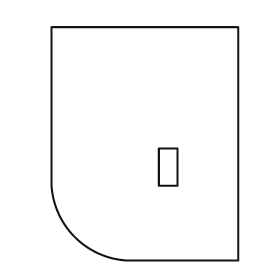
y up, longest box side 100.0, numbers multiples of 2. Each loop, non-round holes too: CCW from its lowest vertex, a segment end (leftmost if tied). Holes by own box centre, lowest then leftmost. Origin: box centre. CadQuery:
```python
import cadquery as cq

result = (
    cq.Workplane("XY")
    .moveTo(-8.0, -50.0)
    .lineTo(40.0, -50.0)
    .lineTo(40.0, 50.0)
    .lineTo(-40.0, 50.0)
    .lineTo(-40.0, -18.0)
    .threePointArc((-30.0, -40.0), (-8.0, -50.0))
    .close()
    .moveTo(6.0, -18.0)
    .lineTo(14.0, -18.0)
    .lineTo(14.0, -2.0)
    .lineTo(6.0, -2.0)
    .close()
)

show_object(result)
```